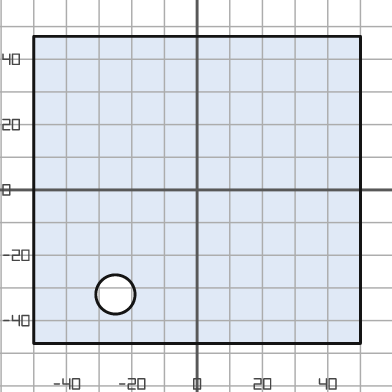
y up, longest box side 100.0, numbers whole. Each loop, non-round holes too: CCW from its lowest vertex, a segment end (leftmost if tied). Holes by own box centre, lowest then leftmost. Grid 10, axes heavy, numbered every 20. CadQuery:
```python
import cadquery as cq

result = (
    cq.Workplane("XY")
    .moveTo(-50.0, -47.0)
    .lineTo(50.0, -47.0)
    .lineTo(50.0, 47.0)
    .lineTo(-50.0, 47.0)
    .close()
    .moveTo(-25.0, -32.0)
    .circle(6.0)
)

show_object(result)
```